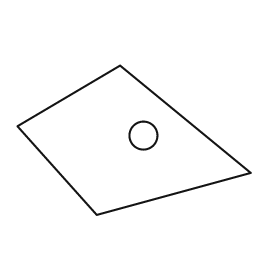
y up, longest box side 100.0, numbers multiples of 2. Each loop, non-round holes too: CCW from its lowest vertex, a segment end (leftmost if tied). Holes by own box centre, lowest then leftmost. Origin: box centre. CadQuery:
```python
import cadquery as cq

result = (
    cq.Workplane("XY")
    .moveTo(-16.0, -32.0)
    .lineTo(50.0, -14.0)
    .lineTo(-6.0, 32.0)
    .lineTo(-50.0, 6.0)
    .close()
    .moveTo(4.0, 2.0)
    .circle(6.0)
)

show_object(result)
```